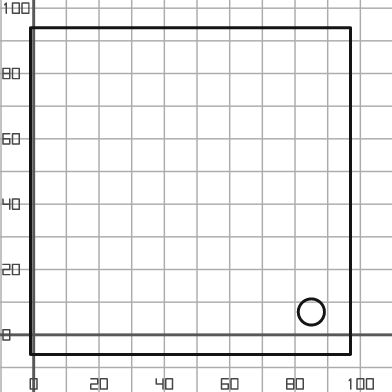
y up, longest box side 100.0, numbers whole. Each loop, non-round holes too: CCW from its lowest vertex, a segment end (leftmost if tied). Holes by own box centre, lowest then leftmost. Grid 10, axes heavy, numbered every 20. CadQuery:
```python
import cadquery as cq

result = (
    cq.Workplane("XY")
    .moveTo(-1.0, -6.0)
    .lineTo(97.0, -6.0)
    .lineTo(97.0, 94.0)
    .lineTo(-1.0, 94.0)
    .close()
    .moveTo(85.0, 7.0)
    .circle(4.0)
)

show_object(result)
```